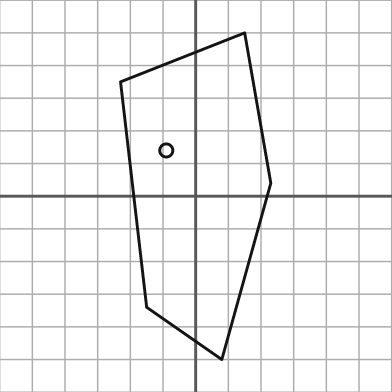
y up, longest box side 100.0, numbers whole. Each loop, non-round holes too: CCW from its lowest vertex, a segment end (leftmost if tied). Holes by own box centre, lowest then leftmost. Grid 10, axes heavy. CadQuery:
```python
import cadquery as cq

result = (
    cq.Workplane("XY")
    .moveTo(8.0, -50.0)
    .lineTo(23.0, 4.0)
    .lineTo(15.0, 50.0)
    .lineTo(-23.0, 35.0)
    .lineTo(-15.0, -34.0)
    .close()
    .moveTo(-9.0, 14.0)
    .circle(2.0)
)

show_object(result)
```